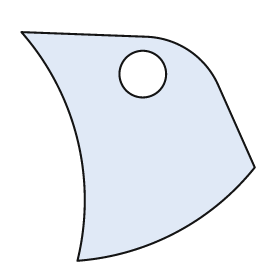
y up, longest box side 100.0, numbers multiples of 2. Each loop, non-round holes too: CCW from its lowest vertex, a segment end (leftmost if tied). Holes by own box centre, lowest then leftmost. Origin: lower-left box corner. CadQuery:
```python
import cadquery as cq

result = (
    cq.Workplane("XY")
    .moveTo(24.0, 0.0)
    .threePointArc((66.0, 12.0), (100.0, 40.0))
    .lineTo(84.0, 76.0)
    .threePointArc((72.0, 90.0), (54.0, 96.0))
    .lineTo(0.0, 98.0)
    .threePointArc((24.0, 52.0), (24.0, 0.0))
    .close()
    .moveTo(52.0, 80.0)
    .circle(10.0)
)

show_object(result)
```